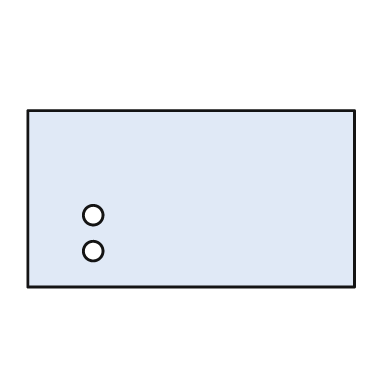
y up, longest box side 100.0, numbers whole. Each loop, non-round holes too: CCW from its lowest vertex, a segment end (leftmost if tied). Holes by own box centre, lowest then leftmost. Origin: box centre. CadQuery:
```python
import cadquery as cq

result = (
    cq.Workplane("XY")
    .moveTo(-50.0, -27.0)
    .lineTo(50.0, -27.0)
    .lineTo(50.0, 27.0)
    .lineTo(-50.0, 27.0)
    .close()
    .moveTo(-30.0, -16.0)
    .circle(3.0)
    .moveTo(-30.0, -5.0)
    .circle(3.0)
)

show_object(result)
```